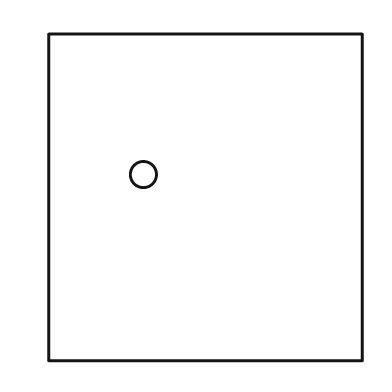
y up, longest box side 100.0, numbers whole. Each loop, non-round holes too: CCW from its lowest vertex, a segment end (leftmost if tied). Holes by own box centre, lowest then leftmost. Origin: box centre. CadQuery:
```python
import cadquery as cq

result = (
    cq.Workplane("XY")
    .moveTo(-48.0, -50.0)
    .lineTo(48.0, -50.0)
    .lineTo(48.0, 50.0)
    .lineTo(-48.0, 50.0)
    .close()
    .moveTo(-19.0, 7.0)
    .circle(4.0)
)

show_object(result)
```